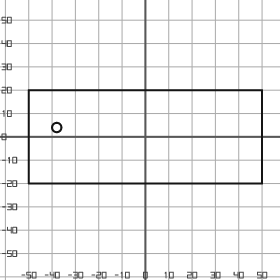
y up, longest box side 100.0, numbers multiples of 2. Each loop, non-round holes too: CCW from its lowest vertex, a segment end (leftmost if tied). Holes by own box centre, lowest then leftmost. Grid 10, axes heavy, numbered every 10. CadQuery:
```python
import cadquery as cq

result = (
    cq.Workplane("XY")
    .moveTo(-50.0, -20.0)
    .lineTo(50.0, -20.0)
    .lineTo(50.0, 20.0)
    .lineTo(-50.0, 20.0)
    .close()
    .moveTo(-38.0, 4.0)
    .circle(2.0)
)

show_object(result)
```